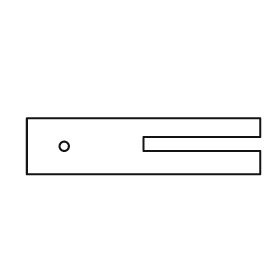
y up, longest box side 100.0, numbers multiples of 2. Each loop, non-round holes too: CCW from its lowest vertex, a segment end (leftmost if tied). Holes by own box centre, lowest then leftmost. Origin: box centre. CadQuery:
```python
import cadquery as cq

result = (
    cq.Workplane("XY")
    .moveTo(-50.0, -12.0)
    .lineTo(50.0, -12.0)
    .lineTo(50.0, -2.0)
    .lineTo(0.0, -2.0)
    .lineTo(0.0, 4.0)
    .lineTo(50.0, 4.0)
    .lineTo(50.0, 12.0)
    .lineTo(-50.0, 12.0)
    .close()
    .moveTo(-34.0, 0.0)
    .circle(2.0)
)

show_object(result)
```